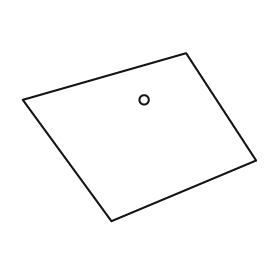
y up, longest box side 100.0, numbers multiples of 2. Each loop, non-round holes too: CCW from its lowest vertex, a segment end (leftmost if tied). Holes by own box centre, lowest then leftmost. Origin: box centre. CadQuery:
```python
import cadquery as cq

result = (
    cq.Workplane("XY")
    .moveTo(-12.0, -36.0)
    .lineTo(50.0, -10.0)
    .lineTo(20.0, 36.0)
    .lineTo(-50.0, 16.0)
    .close()
    .moveTo(2.0, 16.0)
    .circle(2.0)
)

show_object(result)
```